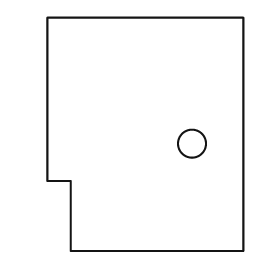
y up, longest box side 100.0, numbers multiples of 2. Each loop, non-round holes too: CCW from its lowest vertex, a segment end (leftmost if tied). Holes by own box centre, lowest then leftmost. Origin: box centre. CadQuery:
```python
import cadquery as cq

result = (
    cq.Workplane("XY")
    .moveTo(-32.0, -50.0)
    .lineTo(42.0, -50.0)
    .lineTo(42.0, 50.0)
    .lineTo(-42.0, 50.0)
    .lineTo(-42.0, -20.0)
    .lineTo(-32.0, -20.0)
    .close()
    .moveTo(20.0, -4.0)
    .circle(6.0)
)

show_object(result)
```